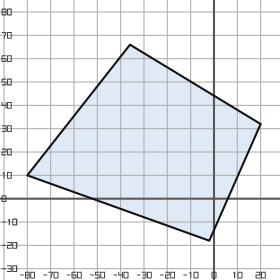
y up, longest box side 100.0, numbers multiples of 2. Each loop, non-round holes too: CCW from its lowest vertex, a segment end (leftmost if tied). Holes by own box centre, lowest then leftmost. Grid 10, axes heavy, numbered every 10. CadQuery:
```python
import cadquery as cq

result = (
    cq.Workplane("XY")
    .moveTo(-2.0, -18.0)
    .lineTo(20.0, 32.0)
    .lineTo(-36.0, 66.0)
    .lineTo(-80.0, 10.0)
    .close()
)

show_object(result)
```